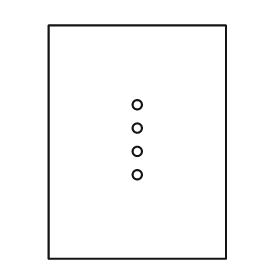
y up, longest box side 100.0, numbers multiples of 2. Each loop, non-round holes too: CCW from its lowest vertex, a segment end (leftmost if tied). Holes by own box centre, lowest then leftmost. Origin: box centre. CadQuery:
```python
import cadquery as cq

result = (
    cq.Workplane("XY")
    .moveTo(-38.0, -50.0)
    .lineTo(38.0, -50.0)
    .lineTo(38.0, 50.0)
    .lineTo(-38.0, 50.0)
    .close()
    .moveTo(0.0, -14.0)
    .circle(2.0)
    .moveTo(0.0, -4.0)
    .circle(2.0)
    .moveTo(0.0, 6.0)
    .circle(2.0)
    .moveTo(0.0, 16.0)
    .circle(2.0)
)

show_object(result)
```